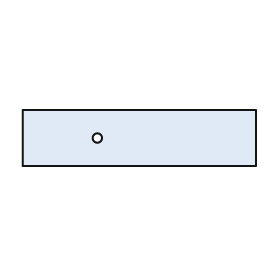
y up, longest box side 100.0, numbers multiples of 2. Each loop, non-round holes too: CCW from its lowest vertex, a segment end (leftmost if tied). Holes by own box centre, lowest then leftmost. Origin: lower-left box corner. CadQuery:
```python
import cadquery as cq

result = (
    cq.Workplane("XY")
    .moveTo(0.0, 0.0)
    .lineTo(100.0, 0.0)
    .lineTo(100.0, 24.0)
    .lineTo(0.0, 24.0)
    .close()
    .moveTo(32.0, 12.0)
    .circle(2.0)
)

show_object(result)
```